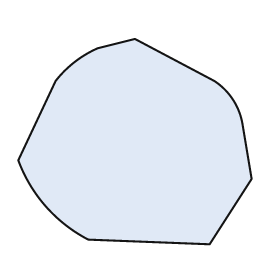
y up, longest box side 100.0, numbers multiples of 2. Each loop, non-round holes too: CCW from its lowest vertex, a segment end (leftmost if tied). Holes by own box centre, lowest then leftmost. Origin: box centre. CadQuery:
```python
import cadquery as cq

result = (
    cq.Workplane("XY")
    .moveTo(32.0, -44.0)
    .lineTo(50.0, -16.0)
    .lineTo(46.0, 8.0)
    .threePointArc((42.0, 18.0), (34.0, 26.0))
    .lineTo(0.0, 44.0)
    .lineTo(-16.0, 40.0)
    .threePointArc((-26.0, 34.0), (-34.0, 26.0))
    .lineTo(-50.0, -8.0)
    .threePointArc((-38.0, -28.0), (-20.0, -42.0))
    .close()
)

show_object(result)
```